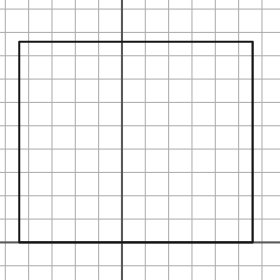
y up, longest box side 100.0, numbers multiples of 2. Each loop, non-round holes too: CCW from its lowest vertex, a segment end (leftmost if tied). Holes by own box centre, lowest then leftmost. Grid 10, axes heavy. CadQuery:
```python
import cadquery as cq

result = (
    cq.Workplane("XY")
    .moveTo(-44.0, 0.0)
    .lineTo(56.0, 0.0)
    .lineTo(56.0, 86.0)
    .lineTo(-44.0, 86.0)
    .close()
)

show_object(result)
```